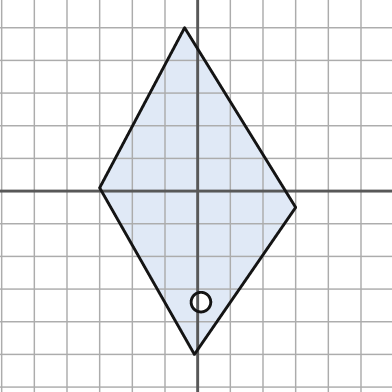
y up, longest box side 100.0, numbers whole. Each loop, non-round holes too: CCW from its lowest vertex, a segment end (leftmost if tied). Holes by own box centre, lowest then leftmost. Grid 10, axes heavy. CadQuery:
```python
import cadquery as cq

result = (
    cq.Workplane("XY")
    .moveTo(-1.0, -50.0)
    .lineTo(30.0, -5.0)
    .lineTo(-4.0, 50.0)
    .lineTo(-30.0, 1.0)
    .close()
    .moveTo(1.0, -34.0)
    .circle(3.0)
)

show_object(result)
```